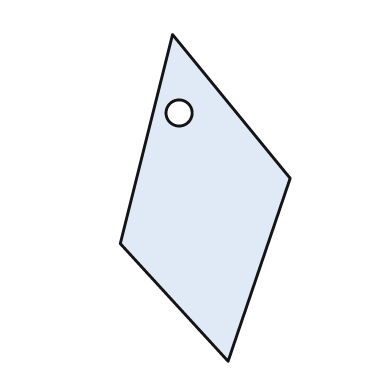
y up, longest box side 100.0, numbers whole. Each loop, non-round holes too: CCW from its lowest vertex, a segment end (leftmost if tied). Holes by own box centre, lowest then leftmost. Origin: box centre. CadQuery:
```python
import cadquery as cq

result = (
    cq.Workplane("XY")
    .moveTo(7.0, -50.0)
    .lineTo(26.0, 6.0)
    .lineTo(-10.0, 50.0)
    .lineTo(-26.0, -14.0)
    .close()
    .moveTo(-8.0, 26.0)
    .circle(4.0)
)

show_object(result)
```